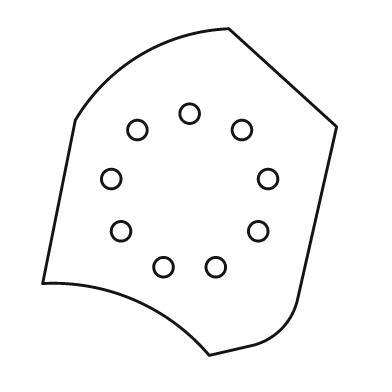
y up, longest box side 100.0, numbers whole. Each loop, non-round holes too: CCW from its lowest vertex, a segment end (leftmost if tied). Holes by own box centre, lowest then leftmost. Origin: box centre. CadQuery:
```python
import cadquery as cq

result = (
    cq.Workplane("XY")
    .moveTo(6.0, -50.0)
    .lineTo(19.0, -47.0)
    .threePointArc((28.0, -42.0), (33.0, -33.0))
    .lineTo(45.0, 20.0)
    .lineTo(12.0, 50.0)
    .threePointArc((-15.0, 42.0), (-35.0, 22.0))
    .lineTo(-45.0, -28.0)
    .threePointArc((-17.0, -33.0), (6.0, -50.0))
    .close()
    .moveTo(-8.0, -23.0)
    .circle(3.0)
    .moveTo(8.0, -23.0)
    .circle(3.0)
    .moveTo(-21.0, -12.0)
    .circle(3.0)
    .moveTo(21.0, -12.0)
    .circle(3.0)
    .moveTo(-24.0, 4.0)
    .circle(3.0)
    .moveTo(24.0, 4.0)
    .circle(3.0)
    .moveTo(-16.0, 19.0)
    .circle(3.0)
    .moveTo(16.0, 19.0)
    .circle(3.0)
    .moveTo(0.0, 24.0)
    .circle(3.0)
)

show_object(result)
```